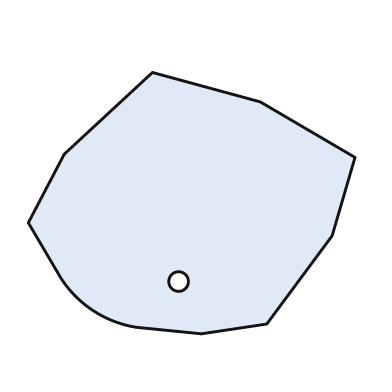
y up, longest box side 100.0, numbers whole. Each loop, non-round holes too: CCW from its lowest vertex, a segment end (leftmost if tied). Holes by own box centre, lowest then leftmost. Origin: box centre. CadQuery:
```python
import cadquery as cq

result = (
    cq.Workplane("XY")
    .moveTo(3.0, -40.0)
    .lineTo(23.0, -37.0)
    .lineTo(43.0, -10.0)
    .lineTo(50.0, 14.0)
    .lineTo(21.0, 31.0)
    .lineTo(-12.0, 40.0)
    .lineTo(-39.0, 15.0)
    .lineTo(-50.0, -6.0)
    .lineTo(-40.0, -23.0)
    .threePointArc((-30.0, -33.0), (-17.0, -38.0))
    .close()
    .moveTo(-4.0, -24.0)
    .circle(3.0)
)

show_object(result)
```